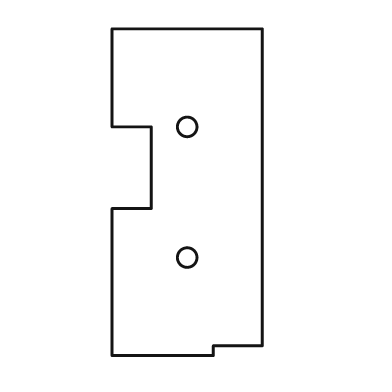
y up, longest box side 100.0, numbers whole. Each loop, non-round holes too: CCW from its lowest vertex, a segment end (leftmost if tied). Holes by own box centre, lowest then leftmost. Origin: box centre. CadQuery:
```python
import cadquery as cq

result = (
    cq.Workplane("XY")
    .moveTo(-23.0, -50.0)
    .lineTo(8.0, -50.0)
    .lineTo(8.0, -47.0)
    .lineTo(23.0, -47.0)
    .lineTo(23.0, 50.0)
    .lineTo(-23.0, 50.0)
    .lineTo(-23.0, 20.0)
    .lineTo(-11.0, 20.0)
    .lineTo(-11.0, -5.0)
    .lineTo(-23.0, -5.0)
    .close()
    .moveTo(0.0, -20.0)
    .circle(3.0)
    .moveTo(0.0, 20.0)
    .circle(3.0)
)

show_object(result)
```